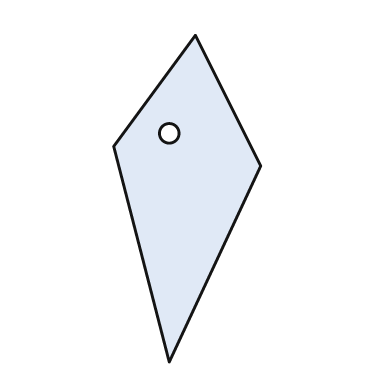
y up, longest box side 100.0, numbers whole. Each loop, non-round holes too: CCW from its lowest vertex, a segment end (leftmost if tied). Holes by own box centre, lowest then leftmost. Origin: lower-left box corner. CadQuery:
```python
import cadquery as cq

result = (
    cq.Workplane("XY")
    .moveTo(17.0, 0.0)
    .lineTo(45.0, 60.0)
    .lineTo(25.0, 100.0)
    .lineTo(0.0, 66.0)
    .close()
    .moveTo(17.0, 70.0)
    .circle(3.0)
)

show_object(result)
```